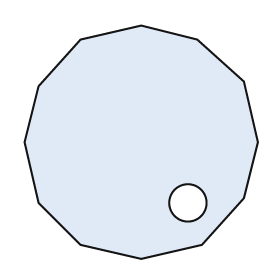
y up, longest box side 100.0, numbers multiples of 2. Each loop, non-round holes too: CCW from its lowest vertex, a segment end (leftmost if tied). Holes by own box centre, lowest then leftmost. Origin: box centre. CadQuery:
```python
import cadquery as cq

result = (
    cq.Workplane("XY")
    .moveTo(0.0, -50.0)
    .lineTo(26.0, -44.0)
    .lineTo(44.0, -24.0)
    .lineTo(50.0, 0.0)
    .lineTo(44.0, 26.0)
    .lineTo(24.0, 44.0)
    .lineTo(0.0, 50.0)
    .lineTo(-26.0, 44.0)
    .lineTo(-44.0, 24.0)
    .lineTo(-50.0, 0.0)
    .lineTo(-44.0, -26.0)
    .lineTo(-26.0, -44.0)
    .close()
    .moveTo(20.0, -26.0)
    .circle(8.0)
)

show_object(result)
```